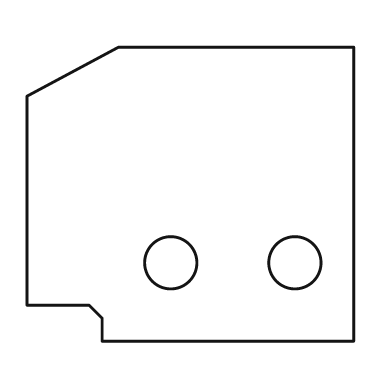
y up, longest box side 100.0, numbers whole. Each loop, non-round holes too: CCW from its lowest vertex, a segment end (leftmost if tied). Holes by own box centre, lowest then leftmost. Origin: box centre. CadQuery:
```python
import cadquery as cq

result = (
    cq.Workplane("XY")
    .moveTo(-27.0, -45.0)
    .lineTo(50.0, -45.0)
    .lineTo(50.0, 45.0)
    .lineTo(-22.0, 45.0)
    .lineTo(-50.0, 30.0)
    .lineTo(-50.0, -34.0)
    .lineTo(-31.0, -34.0)
    .lineTo(-27.0, -38.0)
    .close()
    .moveTo(-6.0, -21.0)
    .circle(8.0)
    .moveTo(32.0, -21.0)
    .circle(8.0)
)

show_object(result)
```